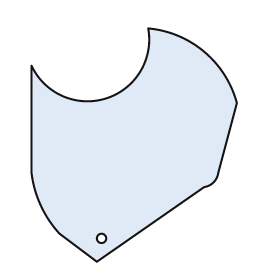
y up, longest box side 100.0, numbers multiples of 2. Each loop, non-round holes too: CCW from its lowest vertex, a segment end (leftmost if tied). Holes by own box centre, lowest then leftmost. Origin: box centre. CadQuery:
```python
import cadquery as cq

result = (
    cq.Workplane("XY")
    .moveTo(-16.0, -50.0)
    .lineTo(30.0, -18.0)
    .threePointArc((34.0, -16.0), (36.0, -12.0))
    .lineTo(44.0, 18.0)
    .threePointArc((30.0, 40.0), (6.0, 50.0))
    .threePointArc((-12.0, 20.0), (-44.0, 34.0))
    .lineTo(-44.0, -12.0)
    .threePointArc((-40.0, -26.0), (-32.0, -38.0))
    .close()
    .moveTo(-14.0, -40.0)
    .circle(2.0)
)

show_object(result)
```